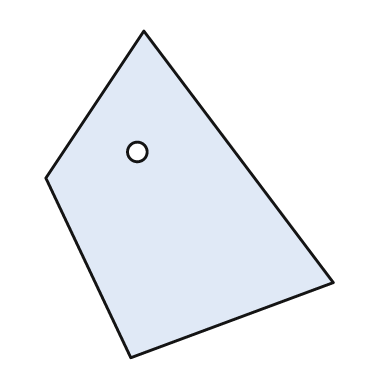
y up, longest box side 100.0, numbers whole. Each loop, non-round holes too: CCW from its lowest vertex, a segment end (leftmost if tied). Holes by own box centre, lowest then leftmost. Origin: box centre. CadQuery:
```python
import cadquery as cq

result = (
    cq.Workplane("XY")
    .moveTo(-18.0, -50.0)
    .lineTo(44.0, -27.0)
    .lineTo(-14.0, 50.0)
    .lineTo(-44.0, 5.0)
    .close()
    .moveTo(-16.0, 13.0)
    .circle(3.0)
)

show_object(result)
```